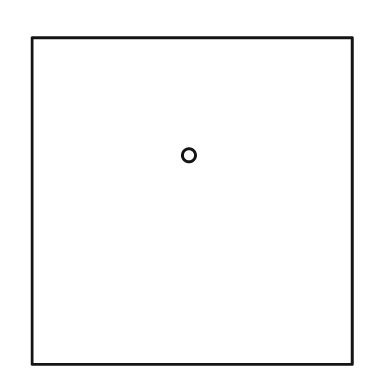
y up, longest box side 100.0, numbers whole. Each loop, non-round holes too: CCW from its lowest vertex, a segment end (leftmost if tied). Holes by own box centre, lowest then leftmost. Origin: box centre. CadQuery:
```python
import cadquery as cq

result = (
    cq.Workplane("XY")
    .moveTo(-49.0, -50.0)
    .lineTo(49.0, -50.0)
    .lineTo(49.0, 50.0)
    .lineTo(-49.0, 50.0)
    .close()
    .moveTo(-1.0, 14.0)
    .circle(2.0)
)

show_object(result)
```